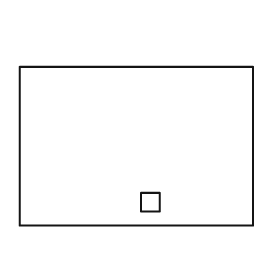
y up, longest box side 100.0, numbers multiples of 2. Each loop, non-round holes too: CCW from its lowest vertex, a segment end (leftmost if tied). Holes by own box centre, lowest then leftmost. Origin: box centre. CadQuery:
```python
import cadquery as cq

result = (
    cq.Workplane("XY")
    .moveTo(-50.0, -34.0)
    .lineTo(50.0, -34.0)
    .lineTo(50.0, 34.0)
    .lineTo(-50.0, 34.0)
    .close()
    .moveTo(2.0, -28.0)
    .lineTo(10.0, -28.0)
    .lineTo(10.0, -20.0)
    .lineTo(2.0, -20.0)
    .close()
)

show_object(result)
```